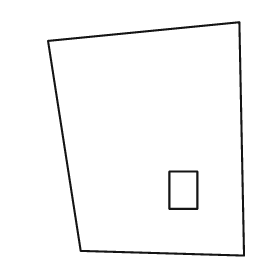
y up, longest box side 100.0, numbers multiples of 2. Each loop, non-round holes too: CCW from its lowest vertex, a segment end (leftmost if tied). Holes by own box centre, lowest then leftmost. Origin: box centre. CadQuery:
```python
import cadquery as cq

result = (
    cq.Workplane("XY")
    .moveTo(42.0, -50.0)
    .lineTo(40.0, 50.0)
    .lineTo(-42.0, 42.0)
    .lineTo(-28.0, -48.0)
    .close()
    .moveTo(10.0, -30.0)
    .lineTo(22.0, -30.0)
    .lineTo(22.0, -14.0)
    .lineTo(10.0, -14.0)
    .close()
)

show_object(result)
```